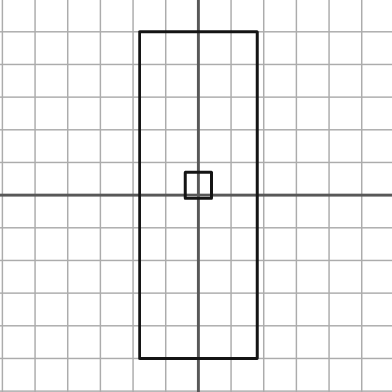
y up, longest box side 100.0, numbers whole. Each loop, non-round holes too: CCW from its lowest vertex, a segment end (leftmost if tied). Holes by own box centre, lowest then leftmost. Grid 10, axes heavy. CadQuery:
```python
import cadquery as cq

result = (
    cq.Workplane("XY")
    .moveTo(-18.0, -50.0)
    .lineTo(18.0, -50.0)
    .lineTo(18.0, 50.0)
    .lineTo(-18.0, 50.0)
    .close()
    .moveTo(-4.0, -1.0)
    .lineTo(4.0, -1.0)
    .lineTo(4.0, 7.0)
    .lineTo(-4.0, 7.0)
    .close()
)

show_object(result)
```